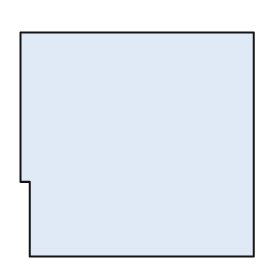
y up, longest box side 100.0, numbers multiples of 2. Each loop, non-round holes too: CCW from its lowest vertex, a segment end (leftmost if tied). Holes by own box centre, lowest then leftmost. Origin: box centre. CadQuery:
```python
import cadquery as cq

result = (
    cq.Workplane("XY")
    .moveTo(-46.0, -48.0)
    .lineTo(50.0, -48.0)
    .lineTo(50.0, 48.0)
    .lineTo(-50.0, 48.0)
    .lineTo(-50.0, -16.0)
    .lineTo(-46.0, -16.0)
    .close()
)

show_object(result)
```